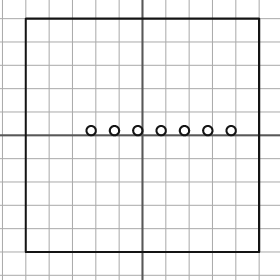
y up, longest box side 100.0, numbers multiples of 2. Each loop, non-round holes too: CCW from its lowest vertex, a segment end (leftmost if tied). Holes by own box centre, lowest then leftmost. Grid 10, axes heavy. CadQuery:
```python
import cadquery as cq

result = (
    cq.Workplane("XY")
    .moveTo(-50.0, -50.0)
    .lineTo(50.0, -50.0)
    .lineTo(50.0, 50.0)
    .lineTo(-50.0, 50.0)
    .close()
    .moveTo(-22.0, 2.0)
    .circle(2.0)
    .moveTo(-12.0, 2.0)
    .circle(2.0)
    .moveTo(-2.0, 2.0)
    .circle(2.0)
    .moveTo(8.0, 2.0)
    .circle(2.0)
    .moveTo(18.0, 2.0)
    .circle(2.0)
    .moveTo(28.0, 2.0)
    .circle(2.0)
    .moveTo(38.0, 2.0)
    .circle(2.0)
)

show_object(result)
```